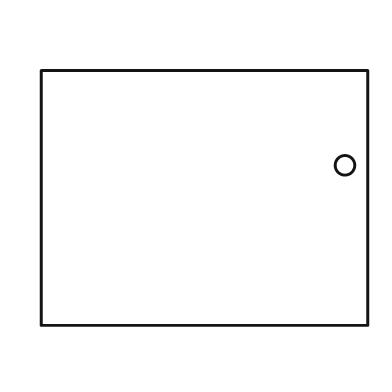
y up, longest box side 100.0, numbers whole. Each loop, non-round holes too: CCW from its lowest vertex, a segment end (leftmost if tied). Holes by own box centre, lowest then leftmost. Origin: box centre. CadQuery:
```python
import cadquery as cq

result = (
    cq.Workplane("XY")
    .moveTo(-50.0, -39.0)
    .lineTo(50.0, -39.0)
    .lineTo(50.0, 39.0)
    .lineTo(-50.0, 39.0)
    .close()
    .moveTo(43.0, 10.0)
    .circle(3.0)
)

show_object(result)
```